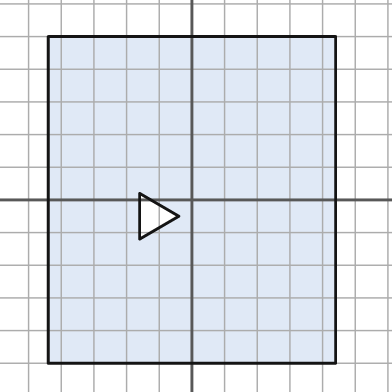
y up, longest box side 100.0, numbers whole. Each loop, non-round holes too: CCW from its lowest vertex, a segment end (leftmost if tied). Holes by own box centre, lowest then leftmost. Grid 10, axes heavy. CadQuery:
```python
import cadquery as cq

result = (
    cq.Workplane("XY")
    .moveTo(-44.0, -50.0)
    .lineTo(44.0, -50.0)
    .lineTo(44.0, 50.0)
    .lineTo(-44.0, 50.0)
    .close()
    .moveTo(-16.0, -12.0)
    .lineTo(-4.0, -5.0)
    .lineTo(-16.0, 2.0)
    .close()
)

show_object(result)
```